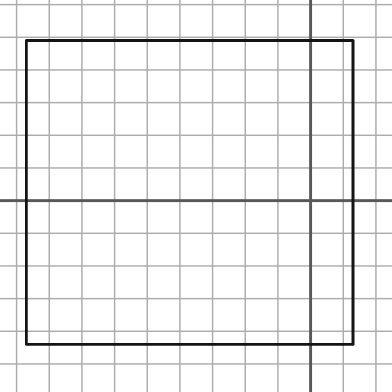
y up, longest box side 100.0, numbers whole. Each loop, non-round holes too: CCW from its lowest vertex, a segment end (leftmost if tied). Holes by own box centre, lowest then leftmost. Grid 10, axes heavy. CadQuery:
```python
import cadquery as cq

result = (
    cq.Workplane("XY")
    .moveTo(-87.0, -44.0)
    .lineTo(13.0, -44.0)
    .lineTo(13.0, 49.0)
    .lineTo(-87.0, 49.0)
    .close()
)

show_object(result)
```